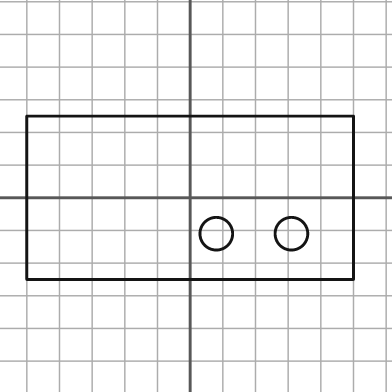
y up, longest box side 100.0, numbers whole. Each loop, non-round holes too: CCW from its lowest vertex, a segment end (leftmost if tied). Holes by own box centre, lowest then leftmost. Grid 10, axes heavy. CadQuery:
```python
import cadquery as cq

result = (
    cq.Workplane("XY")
    .moveTo(-50.0, -25.0)
    .lineTo(50.0, -25.0)
    .lineTo(50.0, 25.0)
    .lineTo(-50.0, 25.0)
    .close()
    .moveTo(8.0, -11.0)
    .circle(5.0)
    .moveTo(31.0, -11.0)
    .circle(5.0)
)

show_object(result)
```